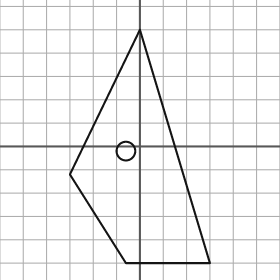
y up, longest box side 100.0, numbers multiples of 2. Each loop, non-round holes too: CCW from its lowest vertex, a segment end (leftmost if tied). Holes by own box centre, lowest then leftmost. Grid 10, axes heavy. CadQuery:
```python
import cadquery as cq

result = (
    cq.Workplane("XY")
    .moveTo(-6.0, -50.0)
    .lineTo(30.0, -50.0)
    .lineTo(0.0, 50.0)
    .lineTo(-30.0, -12.0)
    .close()
    .moveTo(-6.0, -2.0)
    .circle(4.0)
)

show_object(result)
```